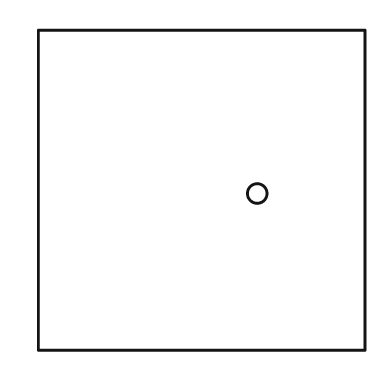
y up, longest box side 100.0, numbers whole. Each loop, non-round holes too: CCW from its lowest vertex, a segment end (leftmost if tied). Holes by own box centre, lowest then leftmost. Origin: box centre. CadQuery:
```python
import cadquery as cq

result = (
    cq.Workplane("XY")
    .moveTo(-50.0, -49.0)
    .lineTo(50.0, -49.0)
    .lineTo(50.0, 49.0)
    .lineTo(-50.0, 49.0)
    .close()
    .moveTo(17.0, -1.0)
    .circle(3.0)
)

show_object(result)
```